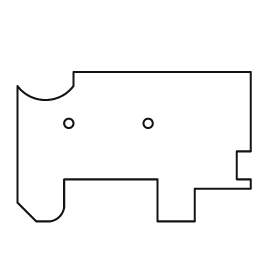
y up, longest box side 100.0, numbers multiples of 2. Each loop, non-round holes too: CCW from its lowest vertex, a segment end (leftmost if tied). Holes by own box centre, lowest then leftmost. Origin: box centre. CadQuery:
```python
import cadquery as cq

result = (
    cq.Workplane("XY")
    .moveTo(-42.0, -32.0)
    .lineTo(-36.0, -32.0)
    .threePointArc((-32.0, -30.0), (-30.0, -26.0))
    .lineTo(-30.0, -14.0)
    .lineTo(10.0, -14.0)
    .lineTo(10.0, -32.0)
    .lineTo(26.0, -32.0)
    .lineTo(26.0, -18.0)
    .lineTo(50.0, -18.0)
    .lineTo(50.0, -14.0)
    .lineTo(44.0, -14.0)
    .lineTo(44.0, -2.0)
    .lineTo(50.0, -2.0)
    .lineTo(50.0, 32.0)
    .lineTo(-26.0, 32.0)
    .lineTo(-26.0, 26.0)
    .threePointArc((-38.0, 20.0), (-50.0, 26.0))
    .lineTo(-50.0, -24.0)
    .close()
    .moveTo(-28.0, 10.0)
    .circle(2.0)
    .moveTo(6.0, 10.0)
    .circle(2.0)
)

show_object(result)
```